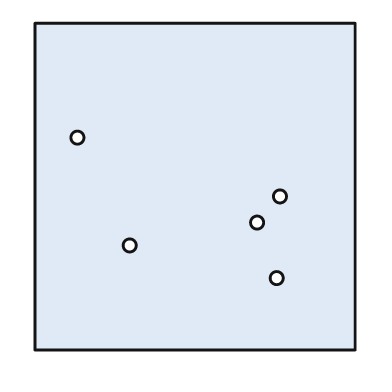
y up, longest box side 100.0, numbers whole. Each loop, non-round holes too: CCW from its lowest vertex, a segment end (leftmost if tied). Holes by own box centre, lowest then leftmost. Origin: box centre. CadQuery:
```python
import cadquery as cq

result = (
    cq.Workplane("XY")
    .moveTo(-49.0, -50.0)
    .lineTo(49.0, -50.0)
    .lineTo(49.0, 50.0)
    .lineTo(-49.0, 50.0)
    .close()
    .moveTo(25.0, -28.0)
    .circle(2.0)
    .moveTo(-20.0, -18.0)
    .circle(2.0)
    .moveTo(19.0, -11.0)
    .circle(2.0)
    .moveTo(26.0, -3.0)
    .circle(2.0)
    .moveTo(-36.0, 15.0)
    .circle(2.0)
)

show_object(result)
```